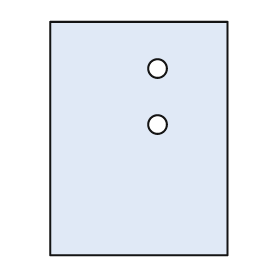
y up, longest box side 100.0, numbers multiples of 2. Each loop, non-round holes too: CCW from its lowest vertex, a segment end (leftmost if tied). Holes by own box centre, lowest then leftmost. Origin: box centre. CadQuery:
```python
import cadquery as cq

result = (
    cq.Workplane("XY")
    .moveTo(-38.0, -50.0)
    .lineTo(38.0, -50.0)
    .lineTo(38.0, 50.0)
    .lineTo(-38.0, 50.0)
    .close()
    .moveTo(8.0, 6.0)
    .circle(4.0)
    .moveTo(8.0, 30.0)
    .circle(4.0)
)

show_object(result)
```